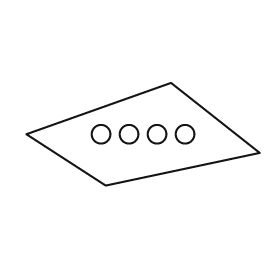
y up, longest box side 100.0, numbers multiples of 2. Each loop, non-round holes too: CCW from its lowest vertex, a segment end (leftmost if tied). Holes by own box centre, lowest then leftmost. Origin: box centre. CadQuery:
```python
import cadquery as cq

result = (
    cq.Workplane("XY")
    .moveTo(-16.0, -22.0)
    .lineTo(50.0, -8.0)
    .lineTo(12.0, 22.0)
    .lineTo(-50.0, 0.0)
    .close()
    .moveTo(-18.0, 0.0)
    .circle(4.0)
    .moveTo(-6.0, 0.0)
    .circle(4.0)
    .moveTo(6.0, 0.0)
    .circle(4.0)
    .moveTo(18.0, 0.0)
    .circle(4.0)
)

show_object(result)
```